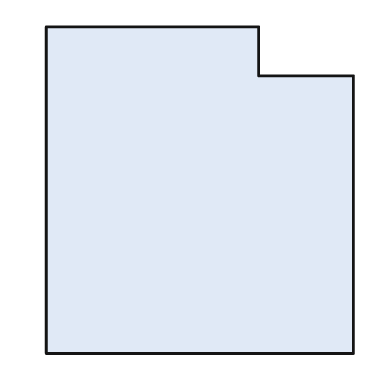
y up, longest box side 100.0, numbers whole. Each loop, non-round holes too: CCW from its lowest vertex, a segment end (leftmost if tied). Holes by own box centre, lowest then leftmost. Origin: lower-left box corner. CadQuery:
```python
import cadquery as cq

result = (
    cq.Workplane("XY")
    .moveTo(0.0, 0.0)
    .lineTo(94.0, 0.0)
    .lineTo(94.0, 85.0)
    .lineTo(65.0, 85.0)
    .lineTo(65.0, 100.0)
    .lineTo(0.0, 100.0)
    .close()
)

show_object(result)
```